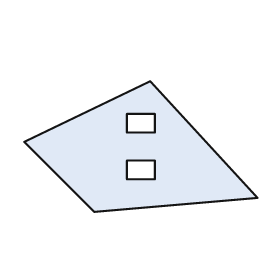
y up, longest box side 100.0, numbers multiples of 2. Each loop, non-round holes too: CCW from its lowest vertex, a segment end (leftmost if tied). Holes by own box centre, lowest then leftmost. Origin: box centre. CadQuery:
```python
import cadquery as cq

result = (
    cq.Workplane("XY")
    .moveTo(-20.0, -28.0)
    .lineTo(50.0, -22.0)
    .lineTo(4.0, 28.0)
    .lineTo(-50.0, 2.0)
    .close()
    .moveTo(-6.0, -14.0)
    .lineTo(6.0, -14.0)
    .lineTo(6.0, -6.0)
    .lineTo(-6.0, -6.0)
    .close()
    .moveTo(-6.0, 6.0)
    .lineTo(6.0, 6.0)
    .lineTo(6.0, 14.0)
    .lineTo(-6.0, 14.0)
    .close()
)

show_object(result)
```